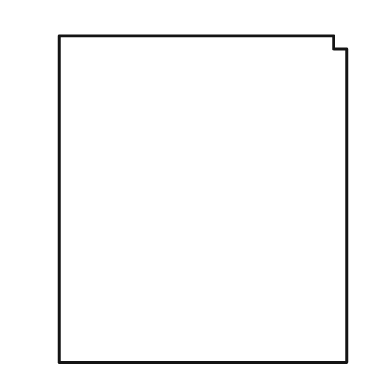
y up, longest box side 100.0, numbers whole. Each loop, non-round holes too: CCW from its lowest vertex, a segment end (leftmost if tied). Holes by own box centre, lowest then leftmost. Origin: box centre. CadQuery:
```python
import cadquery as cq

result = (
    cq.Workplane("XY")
    .moveTo(-44.0, -50.0)
    .lineTo(44.0, -50.0)
    .lineTo(44.0, 46.0)
    .lineTo(40.0, 46.0)
    .lineTo(40.0, 50.0)
    .lineTo(-44.0, 50.0)
    .close()
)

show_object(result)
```